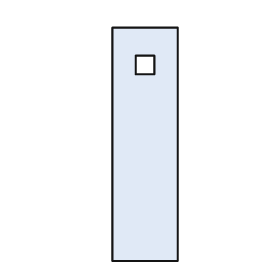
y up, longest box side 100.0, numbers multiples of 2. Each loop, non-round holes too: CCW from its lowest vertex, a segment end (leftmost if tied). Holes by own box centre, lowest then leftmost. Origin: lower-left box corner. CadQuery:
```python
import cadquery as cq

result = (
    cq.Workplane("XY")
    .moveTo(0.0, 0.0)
    .lineTo(28.0, 0.0)
    .lineTo(28.0, 100.0)
    .lineTo(0.0, 100.0)
    .close()
    .moveTo(10.0, 80.0)
    .lineTo(18.0, 80.0)
    .lineTo(18.0, 88.0)
    .lineTo(10.0, 88.0)
    .close()
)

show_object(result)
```